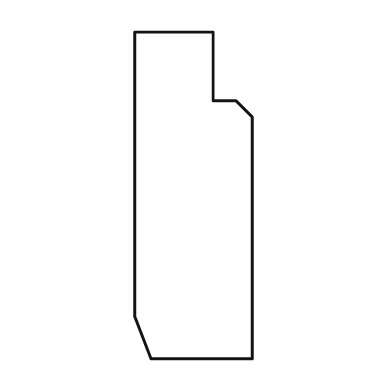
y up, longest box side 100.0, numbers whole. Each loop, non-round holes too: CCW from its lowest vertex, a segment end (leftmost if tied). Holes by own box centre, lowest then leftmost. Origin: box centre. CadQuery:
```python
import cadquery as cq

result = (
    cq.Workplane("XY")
    .moveTo(-13.0, -50.0)
    .lineTo(18.0, -50.0)
    .lineTo(18.0, 24.0)
    .lineTo(13.0, 29.0)
    .lineTo(6.0, 29.0)
    .lineTo(6.0, 50.0)
    .lineTo(-18.0, 50.0)
    .lineTo(-18.0, -37.0)
    .close()
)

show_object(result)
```